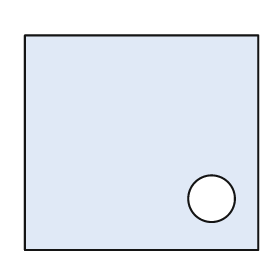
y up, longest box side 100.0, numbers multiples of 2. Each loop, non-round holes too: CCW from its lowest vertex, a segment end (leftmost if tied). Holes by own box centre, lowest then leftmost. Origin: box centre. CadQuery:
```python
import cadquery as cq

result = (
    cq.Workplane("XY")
    .moveTo(-50.0, -46.0)
    .lineTo(50.0, -46.0)
    .lineTo(50.0, 46.0)
    .lineTo(-50.0, 46.0)
    .close()
    .moveTo(30.0, -24.0)
    .circle(10.0)
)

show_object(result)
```